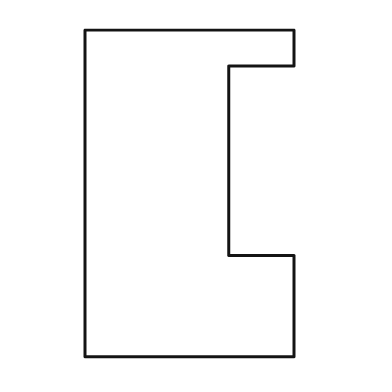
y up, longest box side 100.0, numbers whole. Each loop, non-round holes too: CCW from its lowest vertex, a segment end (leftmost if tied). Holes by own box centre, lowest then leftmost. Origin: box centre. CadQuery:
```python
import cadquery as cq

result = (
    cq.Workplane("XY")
    .moveTo(-32.0, -50.0)
    .lineTo(32.0, -50.0)
    .lineTo(32.0, -19.0)
    .lineTo(12.0, -19.0)
    .lineTo(12.0, 39.0)
    .lineTo(32.0, 39.0)
    .lineTo(32.0, 50.0)
    .lineTo(-32.0, 50.0)
    .close()
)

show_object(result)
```